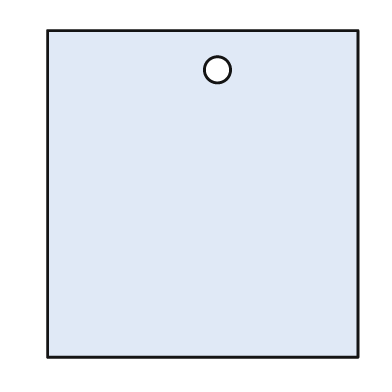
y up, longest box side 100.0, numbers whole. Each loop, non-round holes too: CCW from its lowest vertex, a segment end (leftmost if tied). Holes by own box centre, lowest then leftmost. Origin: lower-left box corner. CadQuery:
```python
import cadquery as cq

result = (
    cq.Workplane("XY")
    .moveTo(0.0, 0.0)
    .lineTo(95.0, 0.0)
    .lineTo(95.0, 100.0)
    .lineTo(0.0, 100.0)
    .close()
    .moveTo(52.0, 88.0)
    .circle(4.0)
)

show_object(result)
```